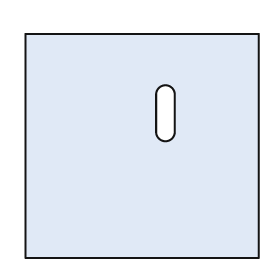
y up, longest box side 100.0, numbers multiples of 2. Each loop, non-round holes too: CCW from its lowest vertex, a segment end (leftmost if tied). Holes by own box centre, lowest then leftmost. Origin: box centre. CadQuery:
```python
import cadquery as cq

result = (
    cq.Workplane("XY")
    .moveTo(-50.0, -48.0)
    .lineTo(50.0, -48.0)
    .lineTo(50.0, 48.0)
    .lineTo(-50.0, 48.0)
    .close()
    .moveTo(6.0, 6.0)
    .threePointArc((10.0, 2.0), (14.0, 6.0))
    .lineTo(14.0, 22.0)
    .threePointArc((10.0, 26.0), (6.0, 22.0))
    .close()
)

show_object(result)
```